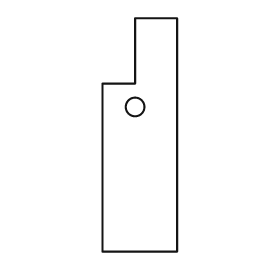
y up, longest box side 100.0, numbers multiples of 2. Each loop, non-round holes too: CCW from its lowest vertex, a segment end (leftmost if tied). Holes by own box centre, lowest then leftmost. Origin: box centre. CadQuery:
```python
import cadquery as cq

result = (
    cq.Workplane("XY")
    .moveTo(-16.0, -50.0)
    .lineTo(16.0, -50.0)
    .lineTo(16.0, 50.0)
    .lineTo(-2.0, 50.0)
    .lineTo(-2.0, 22.0)
    .lineTo(-16.0, 22.0)
    .close()
    .moveTo(-2.0, 12.0)
    .circle(4.0)
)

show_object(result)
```